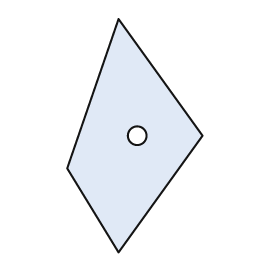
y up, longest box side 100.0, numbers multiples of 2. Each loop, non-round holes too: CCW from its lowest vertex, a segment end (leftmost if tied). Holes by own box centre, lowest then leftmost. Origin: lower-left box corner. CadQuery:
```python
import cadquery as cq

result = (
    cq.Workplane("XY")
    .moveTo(22.0, 0.0)
    .lineTo(58.0, 50.0)
    .lineTo(22.0, 100.0)
    .lineTo(0.0, 36.0)
    .close()
    .moveTo(30.0, 50.0)
    .circle(4.0)
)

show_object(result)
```